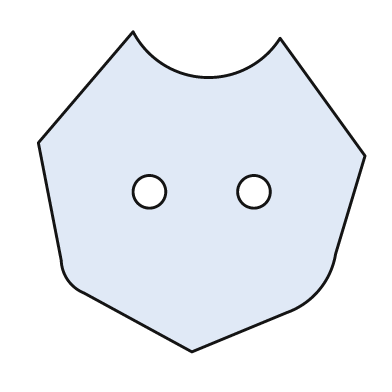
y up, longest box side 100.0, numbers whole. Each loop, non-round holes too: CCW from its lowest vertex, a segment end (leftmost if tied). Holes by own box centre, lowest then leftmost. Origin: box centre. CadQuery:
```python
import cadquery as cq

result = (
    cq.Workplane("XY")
    .moveTo(-3.0, -49.0)
    .lineTo(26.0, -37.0)
    .threePointArc((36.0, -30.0), (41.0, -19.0))
    .lineTo(50.0, 11.0)
    .lineTo(24.0, 47.0)
    .threePointArc((1.0, 35.0), (-21.0, 49.0))
    .lineTo(-50.0, 15.0)
    .lineTo(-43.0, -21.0)
    .threePointArc((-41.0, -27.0), (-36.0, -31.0))
    .close()
    .moveTo(-16.0, 0.0)
    .circle(5.0)
    .moveTo(16.0, 0.0)
    .circle(5.0)
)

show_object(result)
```